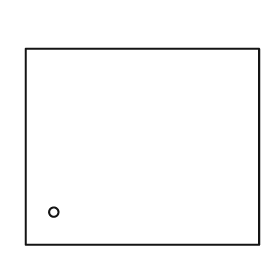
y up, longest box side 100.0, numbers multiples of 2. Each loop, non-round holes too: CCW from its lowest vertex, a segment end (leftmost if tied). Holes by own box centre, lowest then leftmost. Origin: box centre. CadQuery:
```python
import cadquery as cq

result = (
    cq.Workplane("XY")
    .moveTo(-50.0, -42.0)
    .lineTo(50.0, -42.0)
    .lineTo(50.0, 42.0)
    .lineTo(-50.0, 42.0)
    .close()
    .moveTo(-38.0, -28.0)
    .circle(2.0)
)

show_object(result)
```